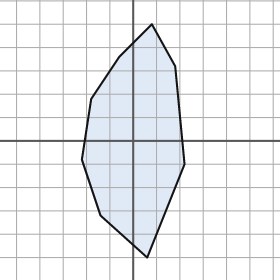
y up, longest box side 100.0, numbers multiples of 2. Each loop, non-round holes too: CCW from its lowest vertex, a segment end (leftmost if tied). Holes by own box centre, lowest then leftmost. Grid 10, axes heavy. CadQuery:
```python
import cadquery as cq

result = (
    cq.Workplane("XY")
    .moveTo(6.0, -50.0)
    .lineTo(22.0, -10.0)
    .lineTo(18.0, 32.0)
    .lineTo(8.0, 50.0)
    .lineTo(-6.0, 36.0)
    .lineTo(-18.0, 18.0)
    .lineTo(-22.0, -8.0)
    .lineTo(-14.0, -32.0)
    .close()
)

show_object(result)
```